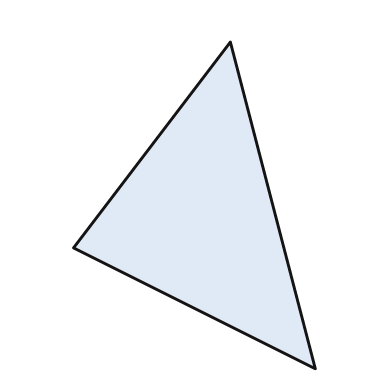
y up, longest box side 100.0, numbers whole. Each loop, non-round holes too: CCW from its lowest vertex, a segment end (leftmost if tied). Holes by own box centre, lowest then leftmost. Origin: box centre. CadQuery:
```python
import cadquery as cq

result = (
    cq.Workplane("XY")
    .moveTo(37.0, -50.0)
    .lineTo(11.0, 50.0)
    .lineTo(-37.0, -13.0)
    .close()
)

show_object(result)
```